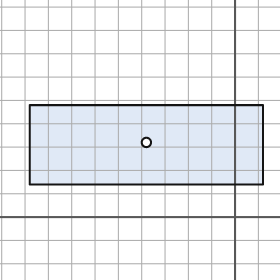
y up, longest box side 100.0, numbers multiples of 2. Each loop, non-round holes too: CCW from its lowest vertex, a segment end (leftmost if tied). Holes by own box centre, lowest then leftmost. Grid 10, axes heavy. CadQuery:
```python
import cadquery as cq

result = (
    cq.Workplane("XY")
    .moveTo(-88.0, 14.0)
    .lineTo(12.0, 14.0)
    .lineTo(12.0, 48.0)
    .lineTo(-88.0, 48.0)
    .close()
    .moveTo(-38.0, 32.0)
    .circle(2.0)
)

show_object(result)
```